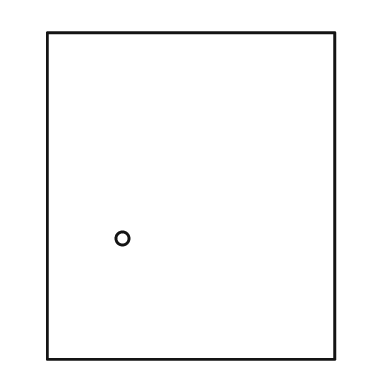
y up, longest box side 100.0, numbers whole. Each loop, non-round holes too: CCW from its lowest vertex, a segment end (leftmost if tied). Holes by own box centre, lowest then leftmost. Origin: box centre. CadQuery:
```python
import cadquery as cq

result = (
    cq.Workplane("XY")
    .moveTo(-44.0, -50.0)
    .lineTo(44.0, -50.0)
    .lineTo(44.0, 50.0)
    .lineTo(-44.0, 50.0)
    .close()
    .moveTo(-21.0, -13.0)
    .circle(2.0)
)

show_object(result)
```